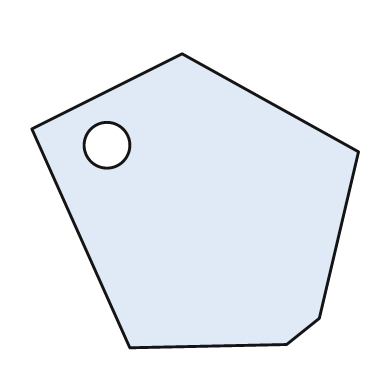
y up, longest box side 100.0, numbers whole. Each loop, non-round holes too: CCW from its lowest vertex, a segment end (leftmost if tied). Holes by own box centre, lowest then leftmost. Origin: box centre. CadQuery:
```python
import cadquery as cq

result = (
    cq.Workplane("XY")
    .moveTo(-20.0, -45.0)
    .lineTo(28.0, -44.0)
    .lineTo(38.0, -36.0)
    .lineTo(50.0, 15.0)
    .lineTo(-4.0, 45.0)
    .lineTo(-50.0, 22.0)
    .close()
    .moveTo(-27.0, 17.0)
    .circle(7.0)
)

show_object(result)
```